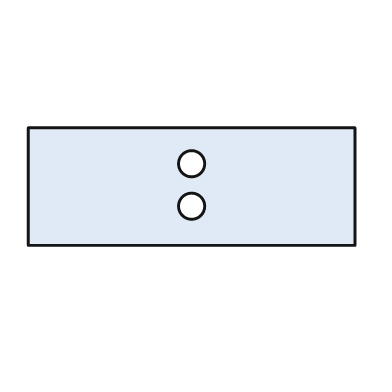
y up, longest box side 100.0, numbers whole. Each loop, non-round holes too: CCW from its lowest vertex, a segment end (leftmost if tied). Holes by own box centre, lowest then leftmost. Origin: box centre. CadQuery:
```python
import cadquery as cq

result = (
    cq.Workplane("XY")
    .moveTo(-50.0, -18.0)
    .lineTo(50.0, -18.0)
    .lineTo(50.0, 18.0)
    .lineTo(-50.0, 18.0)
    .close()
    .moveTo(0.0, -6.0)
    .circle(4.0)
    .moveTo(0.0, 7.0)
    .circle(4.0)
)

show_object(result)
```